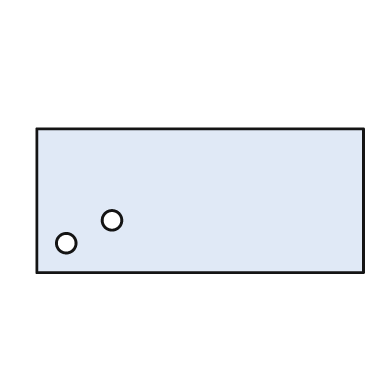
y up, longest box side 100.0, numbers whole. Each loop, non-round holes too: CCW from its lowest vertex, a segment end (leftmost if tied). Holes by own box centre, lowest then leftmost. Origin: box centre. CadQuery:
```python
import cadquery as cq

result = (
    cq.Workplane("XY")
    .moveTo(-50.0, -22.0)
    .lineTo(50.0, -22.0)
    .lineTo(50.0, 22.0)
    .lineTo(-50.0, 22.0)
    .close()
    .moveTo(-41.0, -13.0)
    .circle(3.0)
    .moveTo(-27.0, -6.0)
    .circle(3.0)
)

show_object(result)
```